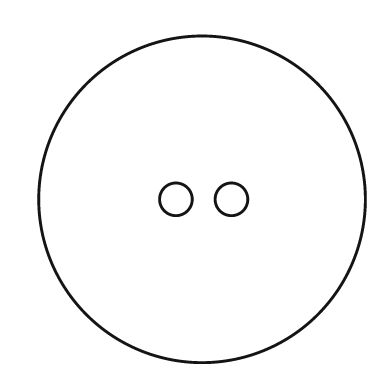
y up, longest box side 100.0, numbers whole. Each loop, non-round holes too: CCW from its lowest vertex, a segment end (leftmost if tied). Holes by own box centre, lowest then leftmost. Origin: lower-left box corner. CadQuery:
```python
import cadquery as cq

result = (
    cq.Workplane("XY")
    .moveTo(50.0, 50.0)
    .circle(50.0)
    .moveTo(42.0, 50.0)
    .circle(5.0)
    .moveTo(59.0, 50.0)
    .circle(5.0)
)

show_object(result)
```